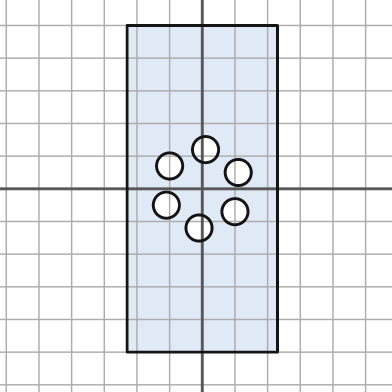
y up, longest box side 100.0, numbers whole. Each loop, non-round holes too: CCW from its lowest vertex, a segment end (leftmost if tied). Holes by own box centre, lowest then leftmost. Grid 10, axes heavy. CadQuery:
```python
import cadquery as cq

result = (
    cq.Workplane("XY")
    .moveTo(-23.0, -50.0)
    .lineTo(23.0, -50.0)
    .lineTo(23.0, 50.0)
    .lineTo(-23.0, 50.0)
    .close()
    .moveTo(-1.0, -12.0)
    .circle(4.0)
    .moveTo(10.0, -7.0)
    .circle(4.0)
    .moveTo(-11.0, -5.0)
    .circle(4.0)
    .moveTo(11.0, 5.0)
    .circle(4.0)
    .moveTo(-10.0, 7.0)
    .circle(4.0)
    .moveTo(1.0, 12.0)
    .circle(4.0)
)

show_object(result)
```